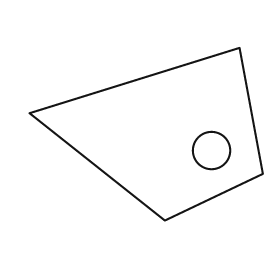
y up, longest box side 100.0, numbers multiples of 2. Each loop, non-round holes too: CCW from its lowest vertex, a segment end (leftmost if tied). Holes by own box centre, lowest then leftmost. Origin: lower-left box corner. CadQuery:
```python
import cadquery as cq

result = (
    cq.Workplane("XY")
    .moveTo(58.0, 0.0)
    .lineTo(100.0, 20.0)
    .lineTo(90.0, 74.0)
    .lineTo(0.0, 46.0)
    .close()
    .moveTo(78.0, 30.0)
    .circle(8.0)
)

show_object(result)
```